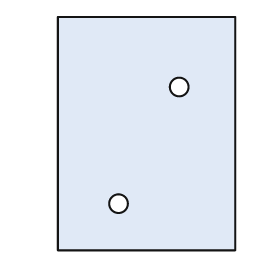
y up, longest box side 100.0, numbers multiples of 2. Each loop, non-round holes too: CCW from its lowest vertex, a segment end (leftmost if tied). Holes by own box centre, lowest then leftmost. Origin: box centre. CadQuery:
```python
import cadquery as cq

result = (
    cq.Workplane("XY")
    .moveTo(-38.0, -50.0)
    .lineTo(38.0, -50.0)
    .lineTo(38.0, 50.0)
    .lineTo(-38.0, 50.0)
    .close()
    .moveTo(-12.0, -30.0)
    .circle(4.0)
    .moveTo(14.0, 20.0)
    .circle(4.0)
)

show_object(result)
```